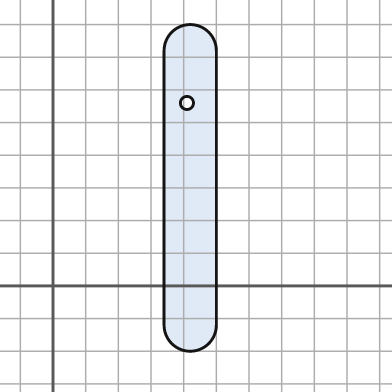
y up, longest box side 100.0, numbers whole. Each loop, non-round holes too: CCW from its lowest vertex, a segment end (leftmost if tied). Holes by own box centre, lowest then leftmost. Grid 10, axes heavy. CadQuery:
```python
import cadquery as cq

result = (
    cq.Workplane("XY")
    .moveTo(34.0, -12.0)
    .threePointArc((42.0, -20.0), (50.0, -12.0))
    .lineTo(50.0, 72.0)
    .threePointArc((42.0, 80.0), (34.0, 72.0))
    .close()
    .moveTo(41.0, 56.0)
    .circle(2.0)
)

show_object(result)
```